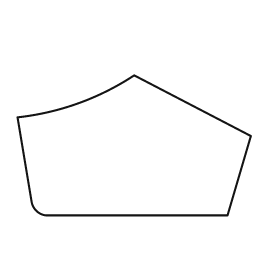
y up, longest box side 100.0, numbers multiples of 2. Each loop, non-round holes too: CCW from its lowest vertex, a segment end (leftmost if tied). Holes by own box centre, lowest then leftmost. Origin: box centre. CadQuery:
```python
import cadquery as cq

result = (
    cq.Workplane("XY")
    .moveTo(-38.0, -30.0)
    .lineTo(40.0, -30.0)
    .lineTo(50.0, 4.0)
    .lineTo(0.0, 30.0)
    .threePointArc((-24.0, 18.0), (-50.0, 12.0))
    .lineTo(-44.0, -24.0)
    .threePointArc((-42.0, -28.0), (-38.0, -30.0))
    .close()
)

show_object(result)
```